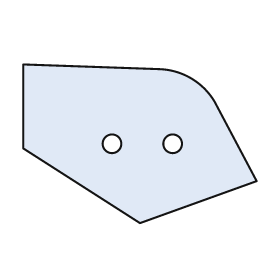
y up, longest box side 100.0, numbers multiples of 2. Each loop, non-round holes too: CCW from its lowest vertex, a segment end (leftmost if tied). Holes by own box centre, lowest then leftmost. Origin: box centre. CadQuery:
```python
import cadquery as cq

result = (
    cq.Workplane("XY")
    .moveTo(0.0, -34.0)
    .lineTo(50.0, -16.0)
    .lineTo(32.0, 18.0)
    .threePointArc((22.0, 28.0), (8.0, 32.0))
    .lineTo(-50.0, 34.0)
    .lineTo(-50.0, -2.0)
    .close()
    .moveTo(-12.0, 0.0)
    .circle(4.0)
    .moveTo(14.0, 0.0)
    .circle(4.0)
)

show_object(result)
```